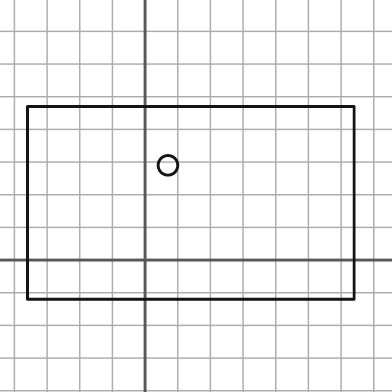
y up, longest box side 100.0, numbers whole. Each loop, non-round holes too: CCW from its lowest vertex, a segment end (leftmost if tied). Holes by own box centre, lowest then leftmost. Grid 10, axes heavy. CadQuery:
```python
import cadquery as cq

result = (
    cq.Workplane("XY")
    .moveTo(-36.0, -12.0)
    .lineTo(64.0, -12.0)
    .lineTo(64.0, 47.0)
    .lineTo(-36.0, 47.0)
    .close()
    .moveTo(7.0, 29.0)
    .circle(3.0)
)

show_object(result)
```